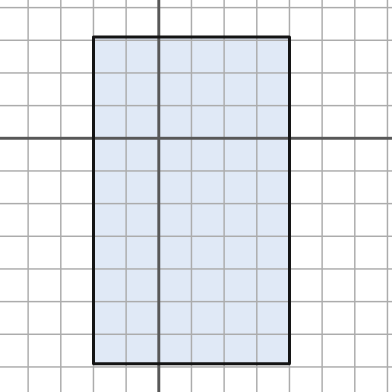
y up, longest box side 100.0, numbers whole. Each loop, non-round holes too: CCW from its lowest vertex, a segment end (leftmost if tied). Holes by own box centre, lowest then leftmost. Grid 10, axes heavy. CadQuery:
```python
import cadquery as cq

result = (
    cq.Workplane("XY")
    .moveTo(-20.0, -69.0)
    .lineTo(40.0, -69.0)
    .lineTo(40.0, 31.0)
    .lineTo(-20.0, 31.0)
    .close()
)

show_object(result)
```